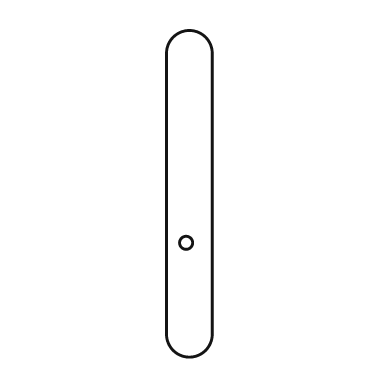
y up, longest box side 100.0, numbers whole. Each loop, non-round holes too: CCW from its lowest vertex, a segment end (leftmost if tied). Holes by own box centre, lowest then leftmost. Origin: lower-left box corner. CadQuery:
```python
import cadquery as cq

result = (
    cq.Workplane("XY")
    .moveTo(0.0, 7.0)
    .threePointArc((7.0, 0.0), (14.0, 7.0))
    .lineTo(14.0, 93.0)
    .threePointArc((7.0, 100.0), (0.0, 93.0))
    .close()
    .moveTo(6.0, 35.0)
    .circle(2.0)
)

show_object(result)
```